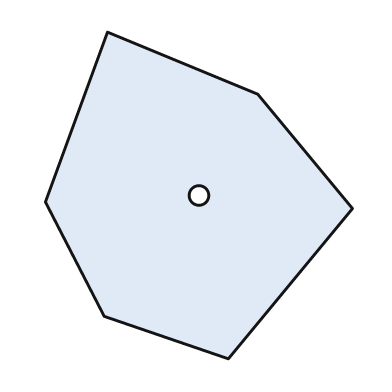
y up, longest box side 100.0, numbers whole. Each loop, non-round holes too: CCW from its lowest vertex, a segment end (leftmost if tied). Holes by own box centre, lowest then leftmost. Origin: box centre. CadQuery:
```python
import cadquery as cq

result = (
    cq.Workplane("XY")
    .moveTo(9.0, -50.0)
    .lineTo(47.0, -4.0)
    .lineTo(18.0, 31.0)
    .lineTo(-28.0, 50.0)
    .lineTo(-47.0, -2.0)
    .lineTo(-29.0, -37.0)
    .close()
    .moveTo(0.0, 0.0)
    .circle(3.0)
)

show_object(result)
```